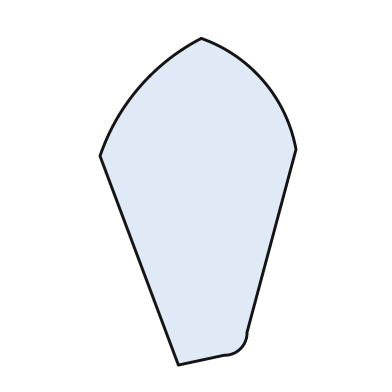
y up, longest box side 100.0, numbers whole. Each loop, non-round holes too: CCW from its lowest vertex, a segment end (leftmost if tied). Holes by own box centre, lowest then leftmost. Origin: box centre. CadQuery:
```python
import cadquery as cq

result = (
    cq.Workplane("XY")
    .moveTo(-6.0, -50.0)
    .lineTo(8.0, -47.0)
    .threePointArc((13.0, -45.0), (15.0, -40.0))
    .lineTo(30.0, 16.0)
    .threePointArc((20.0, 37.0), (1.0, 50.0))
    .threePointArc((-18.0, 35.0), (-30.0, 14.0))
    .close()
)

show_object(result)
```